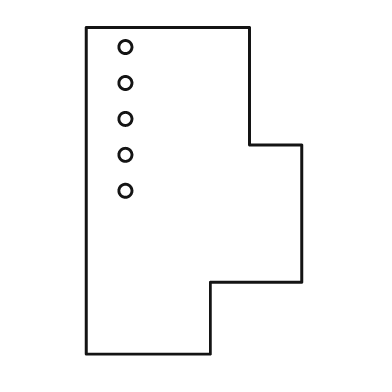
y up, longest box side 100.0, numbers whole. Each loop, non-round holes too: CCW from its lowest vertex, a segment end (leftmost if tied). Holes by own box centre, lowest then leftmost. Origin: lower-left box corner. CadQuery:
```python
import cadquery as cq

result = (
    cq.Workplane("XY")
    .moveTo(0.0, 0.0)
    .lineTo(38.0, 0.0)
    .lineTo(38.0, 22.0)
    .lineTo(66.0, 22.0)
    .lineTo(66.0, 64.0)
    .lineTo(50.0, 64.0)
    .lineTo(50.0, 100.0)
    .lineTo(0.0, 100.0)
    .close()
    .moveTo(12.0, 50.0)
    .circle(2.0)
    .moveTo(12.0, 61.0)
    .circle(2.0)
    .moveTo(12.0, 72.0)
    .circle(2.0)
    .moveTo(12.0, 83.0)
    .circle(2.0)
    .moveTo(12.0, 94.0)
    .circle(2.0)
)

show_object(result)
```